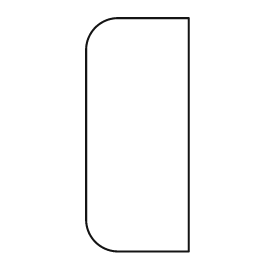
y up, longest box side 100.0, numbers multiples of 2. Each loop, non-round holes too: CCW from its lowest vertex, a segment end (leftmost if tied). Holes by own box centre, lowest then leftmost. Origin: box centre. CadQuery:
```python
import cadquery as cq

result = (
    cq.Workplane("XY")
    .moveTo(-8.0, -50.0)
    .lineTo(22.0, -50.0)
    .lineTo(22.0, 50.0)
    .lineTo(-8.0, 50.0)
    .threePointArc((-18.0, 46.0), (-22.0, 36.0))
    .lineTo(-22.0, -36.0)
    .threePointArc((-18.0, -46.0), (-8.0, -50.0))
    .close()
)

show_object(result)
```